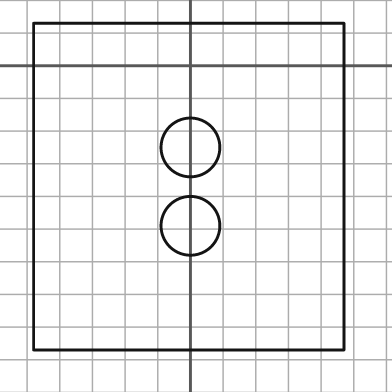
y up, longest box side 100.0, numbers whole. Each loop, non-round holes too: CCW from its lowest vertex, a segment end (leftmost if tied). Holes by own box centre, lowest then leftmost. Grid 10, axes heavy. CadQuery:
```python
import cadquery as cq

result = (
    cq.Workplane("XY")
    .moveTo(-48.0, -87.0)
    .lineTo(47.0, -87.0)
    .lineTo(47.0, 13.0)
    .lineTo(-48.0, 13.0)
    .close()
    .moveTo(0.0, -49.0)
    .circle(9.0)
    .moveTo(0.0, -25.0)
    .circle(9.0)
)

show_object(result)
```